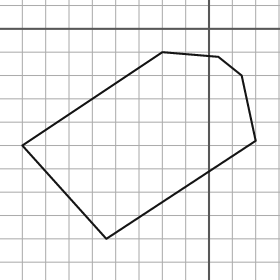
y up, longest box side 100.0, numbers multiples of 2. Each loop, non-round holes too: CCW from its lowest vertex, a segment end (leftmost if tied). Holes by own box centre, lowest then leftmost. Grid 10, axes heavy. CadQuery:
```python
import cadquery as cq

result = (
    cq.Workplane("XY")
    .moveTo(-44.0, -90.0)
    .lineTo(20.0, -48.0)
    .lineTo(14.0, -20.0)
    .lineTo(4.0, -12.0)
    .lineTo(-20.0, -10.0)
    .lineTo(-80.0, -50.0)
    .close()
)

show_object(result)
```